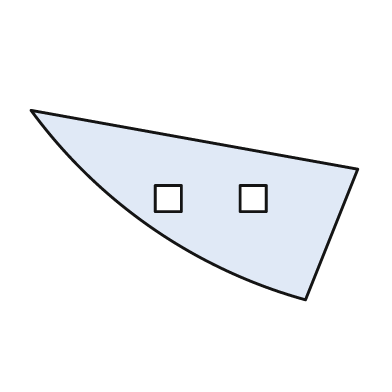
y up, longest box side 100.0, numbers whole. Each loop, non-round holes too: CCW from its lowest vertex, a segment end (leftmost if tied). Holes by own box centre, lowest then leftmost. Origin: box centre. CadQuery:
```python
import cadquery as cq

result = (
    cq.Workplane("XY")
    .moveTo(34.0, -29.0)
    .lineTo(50.0, 11.0)
    .lineTo(-50.0, 29.0)
    .threePointArc((-13.0, -7.0), (34.0, -29.0))
    .close()
    .moveTo(-12.0, -2.0)
    .lineTo(-4.0, -2.0)
    .lineTo(-4.0, 6.0)
    .lineTo(-12.0, 6.0)
    .close()
    .moveTo(14.0, -2.0)
    .lineTo(22.0, -2.0)
    .lineTo(22.0, 6.0)
    .lineTo(14.0, 6.0)
    .close()
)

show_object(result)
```